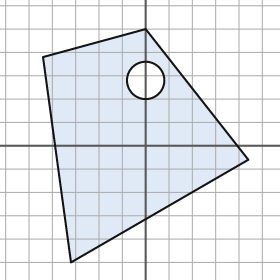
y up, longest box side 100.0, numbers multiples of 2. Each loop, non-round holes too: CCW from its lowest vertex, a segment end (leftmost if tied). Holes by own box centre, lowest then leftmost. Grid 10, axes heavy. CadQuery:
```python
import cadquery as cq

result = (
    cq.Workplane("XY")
    .moveTo(-32.0, -50.0)
    .lineTo(44.0, -6.0)
    .lineTo(0.0, 50.0)
    .lineTo(-44.0, 38.0)
    .close()
    .moveTo(0.0, 28.0)
    .circle(8.0)
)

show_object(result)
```